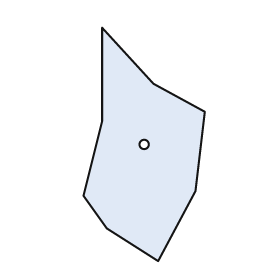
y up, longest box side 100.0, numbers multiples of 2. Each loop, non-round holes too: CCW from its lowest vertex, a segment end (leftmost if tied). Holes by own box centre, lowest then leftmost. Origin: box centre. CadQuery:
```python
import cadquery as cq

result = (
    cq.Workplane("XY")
    .moveTo(6.0, -50.0)
    .lineTo(22.0, -20.0)
    .lineTo(26.0, 14.0)
    .lineTo(4.0, 26.0)
    .lineTo(-18.0, 50.0)
    .lineTo(-18.0, 10.0)
    .lineTo(-26.0, -22.0)
    .lineTo(-16.0, -36.0)
    .close()
    .moveTo(0.0, 0.0)
    .circle(2.0)
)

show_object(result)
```